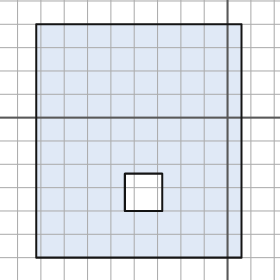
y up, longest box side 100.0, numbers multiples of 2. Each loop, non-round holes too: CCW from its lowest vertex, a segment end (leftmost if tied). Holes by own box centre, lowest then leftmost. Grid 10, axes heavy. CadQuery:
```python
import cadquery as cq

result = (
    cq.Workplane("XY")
    .moveTo(-82.0, -60.0)
    .lineTo(6.0, -60.0)
    .lineTo(6.0, 40.0)
    .lineTo(-82.0, 40.0)
    .close()
    .moveTo(-44.0, -40.0)
    .lineTo(-28.0, -40.0)
    .lineTo(-28.0, -24.0)
    .lineTo(-44.0, -24.0)
    .close()
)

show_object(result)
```